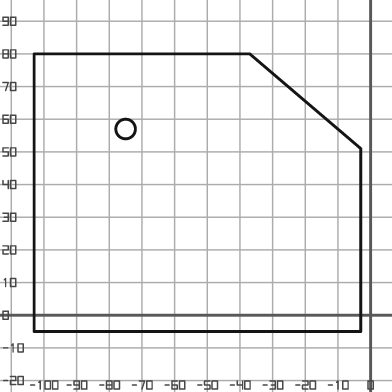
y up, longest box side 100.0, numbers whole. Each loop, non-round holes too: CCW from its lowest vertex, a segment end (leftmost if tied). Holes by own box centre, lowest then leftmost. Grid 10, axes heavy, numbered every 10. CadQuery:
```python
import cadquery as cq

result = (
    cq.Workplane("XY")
    .moveTo(-103.0, -5.0)
    .lineTo(-3.0, -5.0)
    .lineTo(-3.0, 51.0)
    .lineTo(-37.0, 80.0)
    .lineTo(-103.0, 80.0)
    .close()
    .moveTo(-75.0, 57.0)
    .circle(3.0)
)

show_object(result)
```